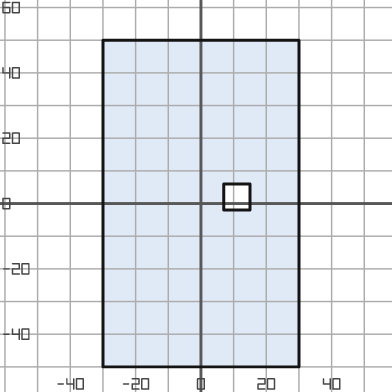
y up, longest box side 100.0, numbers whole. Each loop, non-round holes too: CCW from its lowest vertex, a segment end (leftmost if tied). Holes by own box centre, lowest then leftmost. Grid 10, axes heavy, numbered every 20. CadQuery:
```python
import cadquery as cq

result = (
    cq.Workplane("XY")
    .moveTo(-30.0, -50.0)
    .lineTo(30.0, -50.0)
    .lineTo(30.0, 50.0)
    .lineTo(-30.0, 50.0)
    .close()
    .moveTo(7.0, -2.0)
    .lineTo(15.0, -2.0)
    .lineTo(15.0, 6.0)
    .lineTo(7.0, 6.0)
    .close()
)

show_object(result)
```